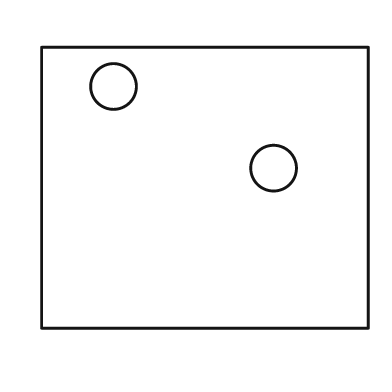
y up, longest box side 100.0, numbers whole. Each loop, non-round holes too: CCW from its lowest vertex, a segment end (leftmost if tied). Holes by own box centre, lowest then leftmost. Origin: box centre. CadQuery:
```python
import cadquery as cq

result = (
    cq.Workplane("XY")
    .moveTo(-50.0, -43.0)
    .lineTo(50.0, -43.0)
    .lineTo(50.0, 43.0)
    .lineTo(-50.0, 43.0)
    .close()
    .moveTo(21.0, 6.0)
    .circle(7.0)
    .moveTo(-28.0, 31.0)
    .circle(7.0)
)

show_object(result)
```